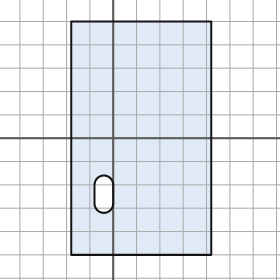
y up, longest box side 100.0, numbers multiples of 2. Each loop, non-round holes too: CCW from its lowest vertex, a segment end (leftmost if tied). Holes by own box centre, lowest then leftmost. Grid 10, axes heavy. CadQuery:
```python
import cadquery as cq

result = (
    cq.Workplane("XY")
    .moveTo(-18.0, -50.0)
    .lineTo(42.0, -50.0)
    .lineTo(42.0, 50.0)
    .lineTo(-18.0, 50.0)
    .close()
    .moveTo(-8.0, -28.0)
    .threePointArc((-4.0, -32.0), (0.0, -28.0))
    .lineTo(0.0, -20.0)
    .threePointArc((-4.0, -16.0), (-8.0, -20.0))
    .close()
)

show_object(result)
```